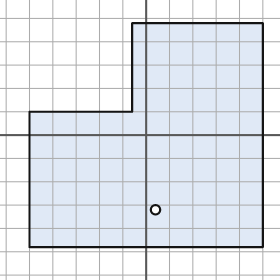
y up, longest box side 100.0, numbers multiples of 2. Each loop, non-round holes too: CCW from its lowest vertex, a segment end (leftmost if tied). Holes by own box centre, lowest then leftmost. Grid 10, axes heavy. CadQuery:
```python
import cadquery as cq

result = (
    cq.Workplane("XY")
    .moveTo(-50.0, -48.0)
    .lineTo(50.0, -48.0)
    .lineTo(50.0, 48.0)
    .lineTo(-6.0, 48.0)
    .lineTo(-6.0, 10.0)
    .lineTo(-50.0, 10.0)
    .close()
    .moveTo(4.0, -32.0)
    .circle(2.0)
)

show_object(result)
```